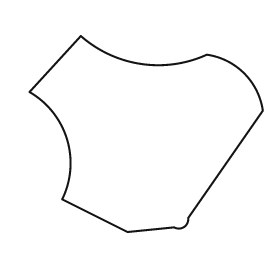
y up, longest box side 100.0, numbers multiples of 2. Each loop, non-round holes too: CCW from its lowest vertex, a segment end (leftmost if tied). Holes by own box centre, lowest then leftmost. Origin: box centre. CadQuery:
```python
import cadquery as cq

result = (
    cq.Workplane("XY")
    .moveTo(-8.0, -42.0)
    .lineTo(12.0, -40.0)
    .threePointArc((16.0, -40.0), (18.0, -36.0))
    .lineTo(50.0, 10.0)
    .threePointArc((42.0, 26.0), (26.0, 34.0))
    .threePointArc((-2.0, 30.0), (-28.0, 42.0))
    .lineTo(-50.0, 18.0)
    .threePointArc((-34.0, -2.0), (-36.0, -28.0))
    .close()
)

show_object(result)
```